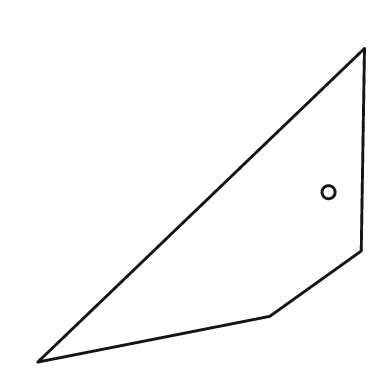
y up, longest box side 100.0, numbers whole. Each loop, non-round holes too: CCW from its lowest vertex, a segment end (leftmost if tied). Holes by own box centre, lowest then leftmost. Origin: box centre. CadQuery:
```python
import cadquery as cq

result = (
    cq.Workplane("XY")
    .moveTo(-50.0, -48.0)
    .lineTo(21.0, -34.0)
    .lineTo(49.0, -14.0)
    .lineTo(50.0, 48.0)
    .close()
    .moveTo(39.0, 4.0)
    .circle(2.0)
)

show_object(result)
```